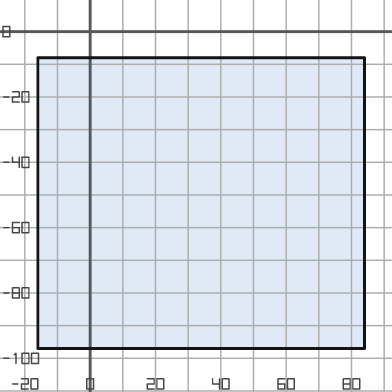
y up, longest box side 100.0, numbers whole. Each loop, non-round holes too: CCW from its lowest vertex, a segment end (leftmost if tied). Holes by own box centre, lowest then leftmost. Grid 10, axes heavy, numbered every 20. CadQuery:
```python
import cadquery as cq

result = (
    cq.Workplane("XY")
    .moveTo(-16.0, -97.0)
    .lineTo(84.0, -97.0)
    .lineTo(84.0, -8.0)
    .lineTo(-16.0, -8.0)
    .close()
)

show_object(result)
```